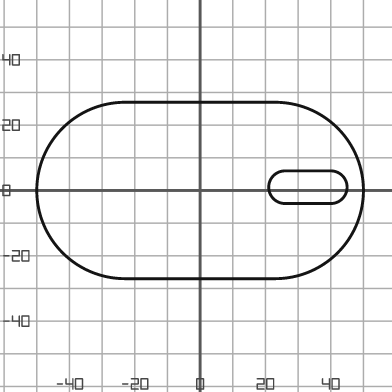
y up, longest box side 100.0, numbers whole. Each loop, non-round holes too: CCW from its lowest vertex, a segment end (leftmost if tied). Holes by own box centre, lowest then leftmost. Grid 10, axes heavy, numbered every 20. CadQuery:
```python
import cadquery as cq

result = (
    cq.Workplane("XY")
    .moveTo(-23.0, -27.0)
    .lineTo(23.0, -27.0)
    .threePointArc((50.0, 0.0), (23.0, 27.0))
    .lineTo(-23.0, 27.0)
    .threePointArc((-50.0, 0.0), (-23.0, -27.0))
    .close()
    .moveTo(26.0, -4.0)
    .lineTo(40.0, -4.0)
    .threePointArc((45.0, 1.0), (40.0, 6.0))
    .lineTo(26.0, 6.0)
    .threePointArc((21.0, 1.0), (26.0, -4.0))
    .close()
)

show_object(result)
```